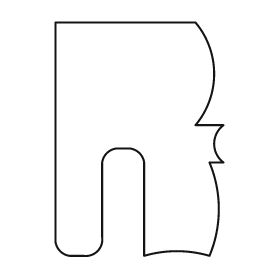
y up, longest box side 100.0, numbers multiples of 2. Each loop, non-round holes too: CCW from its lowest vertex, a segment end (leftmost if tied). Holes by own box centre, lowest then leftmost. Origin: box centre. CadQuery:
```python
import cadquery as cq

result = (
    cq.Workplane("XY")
    .moveTo(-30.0, -50.0)
    .lineTo(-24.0, -50.0)
    .threePointArc((-18.0, -48.0), (-16.0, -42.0))
    .lineTo(-16.0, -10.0)
    .threePointArc((-14.0, -6.0), (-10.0, -4.0))
    .lineTo(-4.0, -4.0)
    .threePointArc((0.0, -6.0), (2.0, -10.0))
    .lineTo(2.0, -50.0)
    .threePointArc((16.0, -48.0), (30.0, -50.0))
    .threePointArc((34.0, -30.0), (30.0, -10.0))
    .lineTo(36.0, -10.0)
    .threePointArc((32.0, -2.0), (36.0, 6.0))
    .lineTo(24.0, 6.0)
    .threePointArc((32.0, 28.0), (24.0, 50.0))
    .lineTo(-36.0, 50.0)
    .lineTo(-36.0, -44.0)
    .threePointArc((-34.0, -48.0), (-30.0, -50.0))
    .close()
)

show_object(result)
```